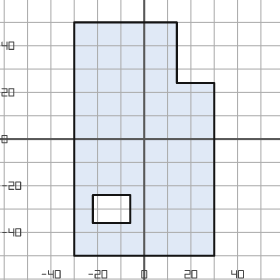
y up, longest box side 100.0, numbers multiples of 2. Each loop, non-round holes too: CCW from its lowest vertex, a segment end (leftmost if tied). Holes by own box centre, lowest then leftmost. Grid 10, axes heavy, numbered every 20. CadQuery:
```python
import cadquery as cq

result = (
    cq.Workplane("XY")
    .moveTo(-30.0, -50.0)
    .lineTo(30.0, -50.0)
    .lineTo(30.0, 24.0)
    .lineTo(14.0, 24.0)
    .lineTo(14.0, 50.0)
    .lineTo(-30.0, 50.0)
    .close()
    .moveTo(-22.0, -36.0)
    .lineTo(-6.0, -36.0)
    .lineTo(-6.0, -24.0)
    .lineTo(-22.0, -24.0)
    .close()
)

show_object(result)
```